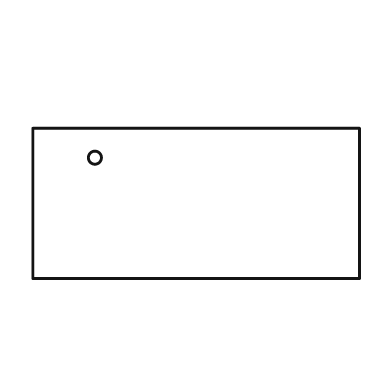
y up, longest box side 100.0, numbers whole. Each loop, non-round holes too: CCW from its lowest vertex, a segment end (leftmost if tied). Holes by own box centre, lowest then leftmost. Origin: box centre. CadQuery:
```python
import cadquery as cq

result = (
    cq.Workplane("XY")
    .moveTo(-50.0, -23.0)
    .lineTo(50.0, -23.0)
    .lineTo(50.0, 23.0)
    .lineTo(-50.0, 23.0)
    .close()
    .moveTo(-31.0, 14.0)
    .circle(2.0)
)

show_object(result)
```